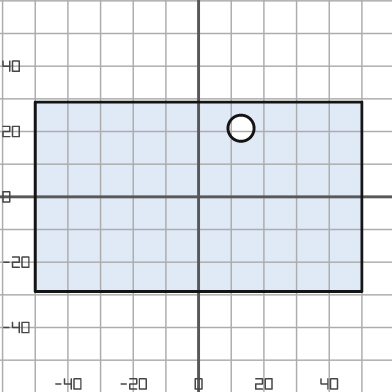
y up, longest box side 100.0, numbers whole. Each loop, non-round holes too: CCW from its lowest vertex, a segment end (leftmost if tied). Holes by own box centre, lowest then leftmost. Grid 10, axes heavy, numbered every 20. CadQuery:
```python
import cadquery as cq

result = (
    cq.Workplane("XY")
    .moveTo(-50.0, -29.0)
    .lineTo(50.0, -29.0)
    .lineTo(50.0, 29.0)
    .lineTo(-50.0, 29.0)
    .close()
    .moveTo(13.0, 21.0)
    .circle(4.0)
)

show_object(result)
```